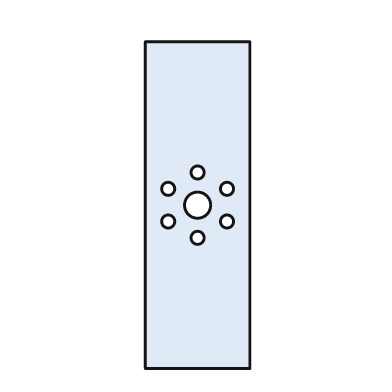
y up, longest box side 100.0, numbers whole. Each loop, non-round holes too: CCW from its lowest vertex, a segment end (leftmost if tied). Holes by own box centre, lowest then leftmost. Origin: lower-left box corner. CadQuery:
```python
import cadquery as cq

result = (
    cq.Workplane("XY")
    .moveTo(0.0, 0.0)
    .lineTo(32.0, 0.0)
    .lineTo(32.0, 100.0)
    .lineTo(0.0, 100.0)
    .close()
    .moveTo(16.0, 40.0)
    .circle(2.0)
    .moveTo(7.0, 45.0)
    .circle(2.0)
    .moveTo(25.0, 45.0)
    .circle(2.0)
    .moveTo(16.0, 50.0)
    .circle(4.0)
    .moveTo(7.0, 55.0)
    .circle(2.0)
    .moveTo(25.0, 55.0)
    .circle(2.0)
    .moveTo(16.0, 60.0)
    .circle(2.0)
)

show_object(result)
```